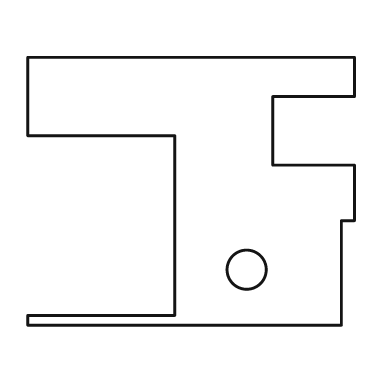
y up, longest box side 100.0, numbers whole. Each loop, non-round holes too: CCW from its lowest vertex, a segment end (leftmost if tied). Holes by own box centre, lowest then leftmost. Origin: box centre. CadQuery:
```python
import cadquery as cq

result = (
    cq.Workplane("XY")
    .moveTo(-50.0, -41.0)
    .lineTo(46.0, -41.0)
    .lineTo(46.0, -9.0)
    .lineTo(50.0, -9.0)
    .lineTo(50.0, 8.0)
    .lineTo(25.0, 8.0)
    .lineTo(25.0, 29.0)
    .lineTo(50.0, 29.0)
    .lineTo(50.0, 41.0)
    .lineTo(-50.0, 41.0)
    .lineTo(-50.0, 17.0)
    .lineTo(-5.0, 17.0)
    .lineTo(-5.0, -38.0)
    .lineTo(-50.0, -38.0)
    .close()
    .moveTo(17.0, -24.0)
    .circle(6.0)
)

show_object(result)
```